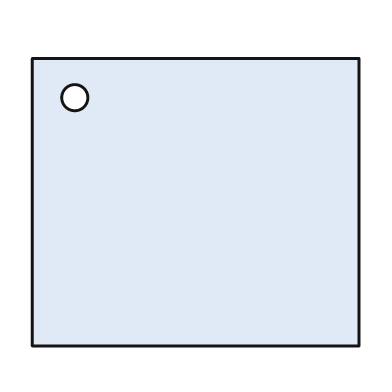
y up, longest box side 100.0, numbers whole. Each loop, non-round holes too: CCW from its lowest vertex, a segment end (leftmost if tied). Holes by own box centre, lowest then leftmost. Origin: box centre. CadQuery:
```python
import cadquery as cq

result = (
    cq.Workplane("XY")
    .moveTo(-50.0, -44.0)
    .lineTo(50.0, -44.0)
    .lineTo(50.0, 44.0)
    .lineTo(-50.0, 44.0)
    .close()
    .moveTo(-37.0, 32.0)
    .circle(4.0)
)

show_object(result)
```